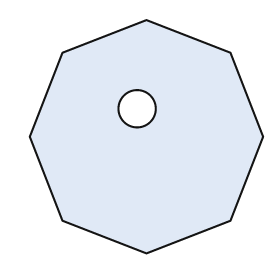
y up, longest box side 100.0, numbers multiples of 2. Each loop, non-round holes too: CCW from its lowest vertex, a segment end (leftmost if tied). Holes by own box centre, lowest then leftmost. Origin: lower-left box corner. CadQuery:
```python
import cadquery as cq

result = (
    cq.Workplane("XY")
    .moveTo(50.0, 0.0)
    .lineTo(86.0, 14.0)
    .lineTo(100.0, 50.0)
    .lineTo(86.0, 86.0)
    .lineTo(50.0, 100.0)
    .lineTo(14.0, 86.0)
    .lineTo(0.0, 50.0)
    .lineTo(14.0, 14.0)
    .close()
    .moveTo(46.0, 62.0)
    .circle(8.0)
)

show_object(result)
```